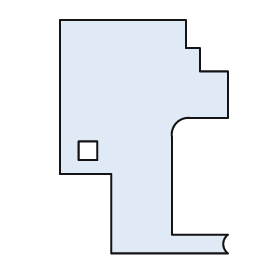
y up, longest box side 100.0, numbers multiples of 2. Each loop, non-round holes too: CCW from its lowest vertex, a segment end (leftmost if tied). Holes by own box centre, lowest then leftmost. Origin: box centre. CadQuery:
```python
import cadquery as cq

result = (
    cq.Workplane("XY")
    .moveTo(-14.0, -50.0)
    .lineTo(36.0, -50.0)
    .threePointArc((34.0, -46.0), (36.0, -42.0))
    .lineTo(12.0, -42.0)
    .lineTo(12.0, 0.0)
    .threePointArc((14.0, 6.0), (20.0, 8.0))
    .lineTo(36.0, 8.0)
    .lineTo(36.0, 28.0)
    .lineTo(24.0, 28.0)
    .lineTo(24.0, 38.0)
    .lineTo(18.0, 38.0)
    .lineTo(18.0, 50.0)
    .lineTo(-36.0, 50.0)
    .lineTo(-36.0, -16.0)
    .lineTo(-14.0, -16.0)
    .close()
    .moveTo(-28.0, -10.0)
    .lineTo(-20.0, -10.0)
    .lineTo(-20.0, -2.0)
    .lineTo(-28.0, -2.0)
    .close()
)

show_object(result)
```